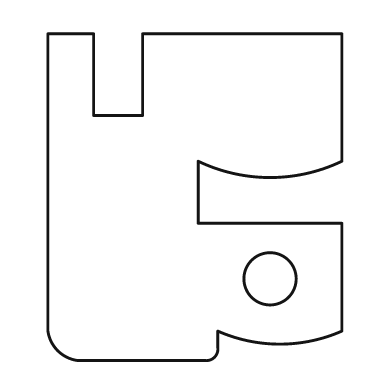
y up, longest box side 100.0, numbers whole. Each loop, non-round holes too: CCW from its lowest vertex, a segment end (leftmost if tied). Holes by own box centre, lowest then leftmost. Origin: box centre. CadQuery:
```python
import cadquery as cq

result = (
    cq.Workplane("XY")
    .moveTo(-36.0, -50.0)
    .lineTo(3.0, -50.0)
    .threePointArc((6.0, -49.0), (7.0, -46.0))
    .lineTo(7.0, -41.0)
    .threePointArc((26.0, -45.0), (45.0, -41.0))
    .lineTo(45.0, -8.0)
    .lineTo(1.0, -8.0)
    .lineTo(1.0, 11.0)
    .threePointArc((23.0, 6.0), (45.0, 11.0))
    .lineTo(45.0, 50.0)
    .lineTo(-16.0, 50.0)
    .lineTo(-16.0, 25.0)
    .lineTo(-31.0, 25.0)
    .lineTo(-31.0, 50.0)
    .lineTo(-45.0, 50.0)
    .lineTo(-45.0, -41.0)
    .threePointArc((-42.0, -47.0), (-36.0, -50.0))
    .close()
    .moveTo(23.0, -25.0)
    .circle(8.0)
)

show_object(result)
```